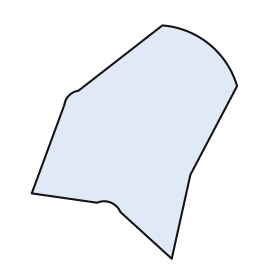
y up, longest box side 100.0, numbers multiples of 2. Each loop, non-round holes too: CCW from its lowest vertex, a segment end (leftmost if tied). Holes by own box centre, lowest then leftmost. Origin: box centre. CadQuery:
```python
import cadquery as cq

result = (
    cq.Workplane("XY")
    .moveTo(16.0, -50.0)
    .lineTo(24.0, -14.0)
    .lineTo(44.0, 24.0)
    .threePointArc((32.0, 42.0), (12.0, 50.0))
    .lineTo(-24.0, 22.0)
    .threePointArc((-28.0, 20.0), (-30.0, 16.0))
    .lineTo(-44.0, -22.0)
    .lineTo(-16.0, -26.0)
    .threePointArc((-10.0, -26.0), (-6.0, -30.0))
    .close()
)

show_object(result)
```